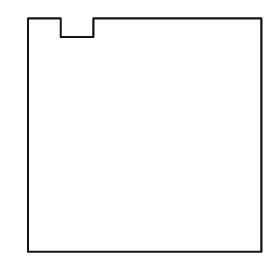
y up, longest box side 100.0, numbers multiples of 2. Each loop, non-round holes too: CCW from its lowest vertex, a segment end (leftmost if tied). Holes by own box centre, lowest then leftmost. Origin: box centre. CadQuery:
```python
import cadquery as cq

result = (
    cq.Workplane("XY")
    .moveTo(-50.0, -50.0)
    .lineTo(50.0, -50.0)
    .lineTo(50.0, 50.0)
    .lineTo(-22.0, 50.0)
    .lineTo(-22.0, 42.0)
    .lineTo(-36.0, 42.0)
    .lineTo(-36.0, 50.0)
    .lineTo(-50.0, 50.0)
    .close()
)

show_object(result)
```